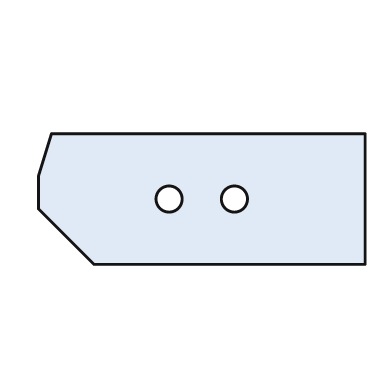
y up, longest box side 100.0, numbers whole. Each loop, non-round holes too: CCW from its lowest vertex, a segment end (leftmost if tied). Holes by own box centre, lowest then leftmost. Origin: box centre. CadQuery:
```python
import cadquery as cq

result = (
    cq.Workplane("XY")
    .moveTo(-33.0, -20.0)
    .lineTo(50.0, -20.0)
    .lineTo(50.0, 20.0)
    .lineTo(-46.0, 20.0)
    .lineTo(-50.0, 7.0)
    .lineTo(-50.0, -3.0)
    .close()
    .moveTo(-10.0, 0.0)
    .circle(4.0)
    .moveTo(10.0, 0.0)
    .circle(4.0)
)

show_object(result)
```